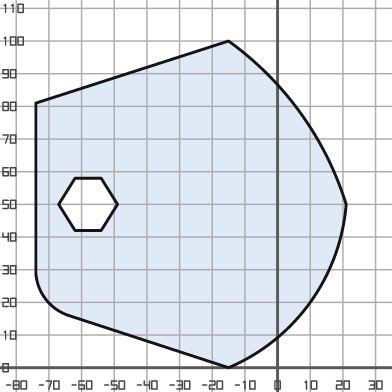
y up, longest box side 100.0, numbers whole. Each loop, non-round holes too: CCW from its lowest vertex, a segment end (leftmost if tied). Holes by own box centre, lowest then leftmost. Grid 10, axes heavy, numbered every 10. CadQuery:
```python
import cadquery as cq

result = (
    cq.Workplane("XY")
    .moveTo(-15.0, 0.0)
    .threePointArc((10.0, 20.0), (21.0, 50.0))
    .threePointArc((7.0, 78.0), (-15.0, 100.0))
    .lineTo(-74.0, 81.0)
    .lineTo(-74.0, 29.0)
    .threePointArc((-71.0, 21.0), (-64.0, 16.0))
    .close()
    .moveTo(-62.0, 42.0)
    .lineTo(-54.0, 42.0)
    .lineTo(-49.0, 50.0)
    .lineTo(-54.0, 58.0)
    .lineTo(-62.0, 58.0)
    .lineTo(-67.0, 50.0)
    .close()
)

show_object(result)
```